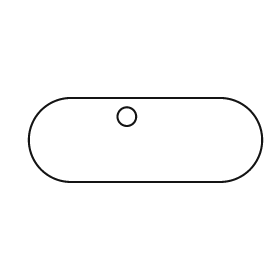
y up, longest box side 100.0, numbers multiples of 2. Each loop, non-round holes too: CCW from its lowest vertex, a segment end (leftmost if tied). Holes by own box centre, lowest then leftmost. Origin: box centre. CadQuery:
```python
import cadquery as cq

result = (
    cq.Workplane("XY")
    .moveTo(-32.0, -18.0)
    .lineTo(32.0, -18.0)
    .threePointArc((50.0, 0.0), (32.0, 18.0))
    .lineTo(-32.0, 18.0)
    .threePointArc((-50.0, 0.0), (-32.0, -18.0))
    .close()
    .moveTo(-8.0, 10.0)
    .circle(4.0)
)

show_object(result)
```